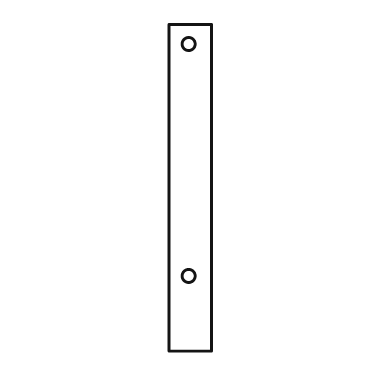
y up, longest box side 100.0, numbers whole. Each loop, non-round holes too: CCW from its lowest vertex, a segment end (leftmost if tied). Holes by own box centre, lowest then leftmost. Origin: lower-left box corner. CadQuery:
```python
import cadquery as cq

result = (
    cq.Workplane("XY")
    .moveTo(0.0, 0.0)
    .lineTo(13.0, 0.0)
    .lineTo(13.0, 100.0)
    .lineTo(0.0, 100.0)
    .close()
    .moveTo(6.0, 23.0)
    .circle(2.0)
    .moveTo(6.0, 94.0)
    .circle(2.0)
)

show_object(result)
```